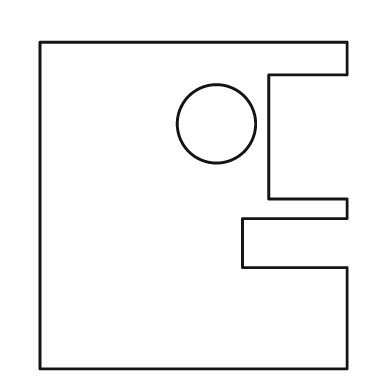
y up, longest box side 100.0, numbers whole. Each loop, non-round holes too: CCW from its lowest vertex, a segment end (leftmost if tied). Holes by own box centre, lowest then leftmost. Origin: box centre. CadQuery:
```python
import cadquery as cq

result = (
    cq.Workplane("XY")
    .moveTo(-47.0, -50.0)
    .lineTo(47.0, -50.0)
    .lineTo(47.0, -19.0)
    .lineTo(15.0, -19.0)
    .lineTo(15.0, -4.0)
    .lineTo(47.0, -4.0)
    .lineTo(47.0, 2.0)
    .lineTo(23.0, 2.0)
    .lineTo(23.0, 40.0)
    .lineTo(47.0, 40.0)
    .lineTo(47.0, 50.0)
    .lineTo(-47.0, 50.0)
    .close()
    .moveTo(7.0, 25.0)
    .circle(12.0)
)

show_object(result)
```